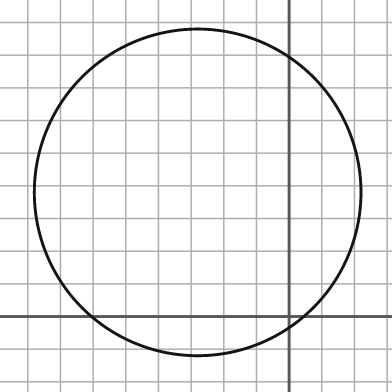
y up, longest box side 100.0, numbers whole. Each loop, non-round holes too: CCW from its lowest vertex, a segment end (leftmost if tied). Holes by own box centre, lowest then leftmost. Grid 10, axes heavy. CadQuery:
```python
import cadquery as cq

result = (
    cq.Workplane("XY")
    .moveTo(-28.0, 38.0)
    .circle(50.0)
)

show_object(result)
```